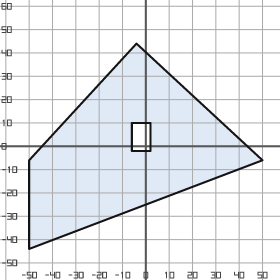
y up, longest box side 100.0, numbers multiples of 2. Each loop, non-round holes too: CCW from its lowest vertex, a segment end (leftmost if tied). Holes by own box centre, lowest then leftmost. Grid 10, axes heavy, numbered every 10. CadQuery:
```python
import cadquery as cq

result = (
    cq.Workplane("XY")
    .moveTo(-50.0, -44.0)
    .lineTo(50.0, -6.0)
    .lineTo(-4.0, 44.0)
    .lineTo(-50.0, -6.0)
    .close()
    .moveTo(-6.0, -2.0)
    .lineTo(2.0, -2.0)
    .lineTo(2.0, 10.0)
    .lineTo(-6.0, 10.0)
    .close()
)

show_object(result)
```